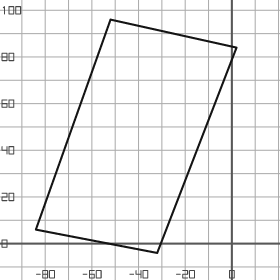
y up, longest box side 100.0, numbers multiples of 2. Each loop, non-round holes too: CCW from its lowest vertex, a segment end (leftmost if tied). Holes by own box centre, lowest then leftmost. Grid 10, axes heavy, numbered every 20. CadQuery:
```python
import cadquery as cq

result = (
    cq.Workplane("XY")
    .moveTo(-32.0, -4.0)
    .lineTo(2.0, 84.0)
    .lineTo(-52.0, 96.0)
    .lineTo(-84.0, 6.0)
    .close()
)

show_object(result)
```